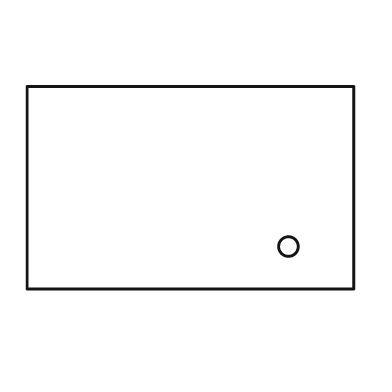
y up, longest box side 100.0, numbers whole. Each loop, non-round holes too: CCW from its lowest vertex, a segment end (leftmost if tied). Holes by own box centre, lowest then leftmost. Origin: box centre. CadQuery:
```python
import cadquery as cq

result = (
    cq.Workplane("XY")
    .moveTo(-50.0, -31.0)
    .lineTo(50.0, -31.0)
    .lineTo(50.0, 31.0)
    .lineTo(-50.0, 31.0)
    .close()
    .moveTo(30.0, -18.0)
    .circle(3.0)
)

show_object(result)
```